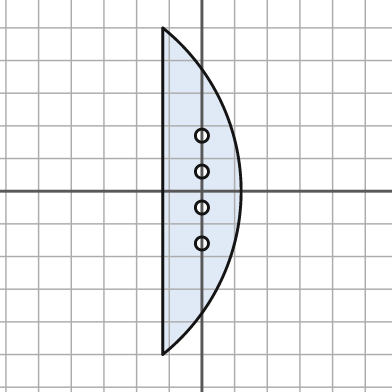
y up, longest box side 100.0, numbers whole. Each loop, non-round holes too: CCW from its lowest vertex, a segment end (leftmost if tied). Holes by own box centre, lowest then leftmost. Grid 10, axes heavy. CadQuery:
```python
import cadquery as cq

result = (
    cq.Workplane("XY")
    .moveTo(-12.0, -50.0)
    .threePointArc((12.0, 0.0), (-12.0, 50.0))
    .close()
    .moveTo(0.0, -16.0)
    .circle(2.0)
    .moveTo(0.0, -5.0)
    .circle(2.0)
    .moveTo(0.0, 6.0)
    .circle(2.0)
    .moveTo(0.0, 17.0)
    .circle(2.0)
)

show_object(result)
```